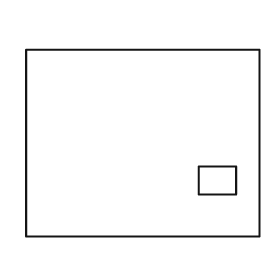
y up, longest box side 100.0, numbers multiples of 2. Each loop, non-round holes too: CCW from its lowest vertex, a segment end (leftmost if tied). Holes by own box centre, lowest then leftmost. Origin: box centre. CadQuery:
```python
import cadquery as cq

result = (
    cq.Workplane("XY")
    .moveTo(-50.0, -40.0)
    .lineTo(50.0, -40.0)
    .lineTo(50.0, 40.0)
    .lineTo(-50.0, 40.0)
    .close()
    .moveTo(24.0, -22.0)
    .lineTo(40.0, -22.0)
    .lineTo(40.0, -10.0)
    .lineTo(24.0, -10.0)
    .close()
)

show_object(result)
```